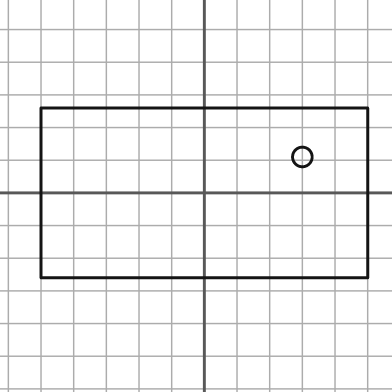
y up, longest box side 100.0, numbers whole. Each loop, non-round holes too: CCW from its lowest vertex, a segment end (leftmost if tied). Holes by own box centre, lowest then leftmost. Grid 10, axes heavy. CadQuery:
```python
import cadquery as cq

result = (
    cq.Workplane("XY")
    .moveTo(-50.0, -26.0)
    .lineTo(50.0, -26.0)
    .lineTo(50.0, 26.0)
    .lineTo(-50.0, 26.0)
    .close()
    .moveTo(30.0, 11.0)
    .circle(3.0)
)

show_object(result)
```